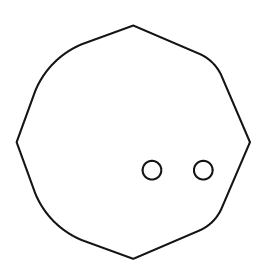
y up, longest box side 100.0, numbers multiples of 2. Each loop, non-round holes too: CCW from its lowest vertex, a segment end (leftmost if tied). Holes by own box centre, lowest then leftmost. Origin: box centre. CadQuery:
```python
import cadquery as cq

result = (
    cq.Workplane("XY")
    .moveTo(0.0, -50.0)
    .lineTo(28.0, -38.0)
    .threePointArc((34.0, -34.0), (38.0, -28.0))
    .lineTo(50.0, 0.0)
    .lineTo(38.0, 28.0)
    .threePointArc((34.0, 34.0), (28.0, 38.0))
    .lineTo(0.0, 50.0)
    .lineTo(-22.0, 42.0)
    .threePointArc((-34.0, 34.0), (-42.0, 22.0))
    .lineTo(-50.0, 0.0)
    .lineTo(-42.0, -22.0)
    .threePointArc((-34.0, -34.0), (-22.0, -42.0))
    .close()
    .moveTo(8.0, -12.0)
    .circle(4.0)
    .moveTo(30.0, -12.0)
    .circle(4.0)
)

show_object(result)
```